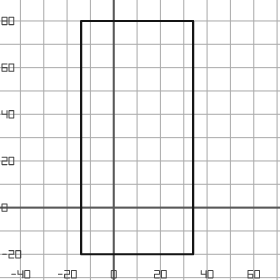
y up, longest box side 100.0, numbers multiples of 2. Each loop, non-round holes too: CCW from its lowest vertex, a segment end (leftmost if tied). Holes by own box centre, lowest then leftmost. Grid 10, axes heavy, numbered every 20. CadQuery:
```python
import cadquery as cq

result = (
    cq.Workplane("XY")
    .moveTo(-14.0, -20.0)
    .lineTo(34.0, -20.0)
    .lineTo(34.0, 80.0)
    .lineTo(-14.0, 80.0)
    .close()
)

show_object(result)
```